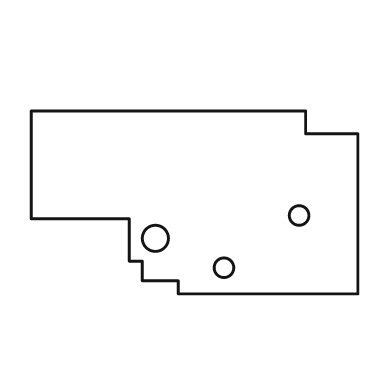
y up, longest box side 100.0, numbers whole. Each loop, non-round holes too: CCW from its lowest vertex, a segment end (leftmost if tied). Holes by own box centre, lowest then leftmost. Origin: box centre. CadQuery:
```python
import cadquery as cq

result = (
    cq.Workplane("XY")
    .moveTo(-5.0, -28.0)
    .lineTo(50.0, -28.0)
    .lineTo(50.0, 21.0)
    .lineTo(34.0, 21.0)
    .lineTo(34.0, 28.0)
    .lineTo(-50.0, 28.0)
    .lineTo(-50.0, -5.0)
    .lineTo(-20.0, -5.0)
    .lineTo(-20.0, -18.0)
    .lineTo(-16.0, -18.0)
    .lineTo(-16.0, -24.0)
    .lineTo(-5.0, -24.0)
    .close()
    .moveTo(9.0, -20.0)
    .circle(3.0)
    .moveTo(-12.0, -11.0)
    .circle(4.0)
    .moveTo(32.0, -4.0)
    .circle(3.0)
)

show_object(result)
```